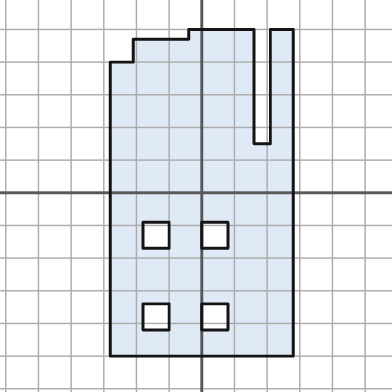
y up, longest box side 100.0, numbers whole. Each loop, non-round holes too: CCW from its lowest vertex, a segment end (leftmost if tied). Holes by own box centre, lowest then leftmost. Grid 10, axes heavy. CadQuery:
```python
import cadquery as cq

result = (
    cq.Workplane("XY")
    .moveTo(-28.0, -50.0)
    .lineTo(28.0, -50.0)
    .lineTo(28.0, 50.0)
    .lineTo(21.0, 50.0)
    .lineTo(21.0, 15.0)
    .lineTo(16.0, 15.0)
    .lineTo(16.0, 50.0)
    .lineTo(-4.0, 50.0)
    .lineTo(-4.0, 47.0)
    .lineTo(-21.0, 47.0)
    .lineTo(-21.0, 40.0)
    .lineTo(-28.0, 40.0)
    .close()
    .moveTo(-18.0, -42.0)
    .lineTo(-10.0, -42.0)
    .lineTo(-10.0, -34.0)
    .lineTo(-18.0, -34.0)
    .close()
    .moveTo(0.0, -42.0)
    .lineTo(8.0, -42.0)
    .lineTo(8.0, -34.0)
    .lineTo(0.0, -34.0)
    .close()
    .moveTo(-18.0, -17.0)
    .lineTo(-10.0, -17.0)
    .lineTo(-10.0, -9.0)
    .lineTo(-18.0, -9.0)
    .close()
    .moveTo(0.0, -17.0)
    .lineTo(8.0, -17.0)
    .lineTo(8.0, -9.0)
    .lineTo(0.0, -9.0)
    .close()
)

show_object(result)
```